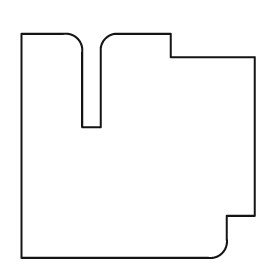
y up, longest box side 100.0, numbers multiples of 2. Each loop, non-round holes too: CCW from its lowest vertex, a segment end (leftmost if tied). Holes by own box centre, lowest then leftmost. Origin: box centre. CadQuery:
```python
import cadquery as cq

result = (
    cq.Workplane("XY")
    .moveTo(-50.0, -48.0)
    .lineTo(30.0, -48.0)
    .threePointArc((36.0, -46.0), (38.0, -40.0))
    .lineTo(38.0, -30.0)
    .lineTo(50.0, -30.0)
    .lineTo(50.0, 38.0)
    .lineTo(14.0, 38.0)
    .lineTo(14.0, 48.0)
    .lineTo(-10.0, 48.0)
    .threePointArc((-14.0, 46.0), (-16.0, 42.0))
    .lineTo(-16.0, 8.0)
    .lineTo(-24.0, 8.0)
    .lineTo(-24.0, 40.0)
    .threePointArc((-26.0, 46.0), (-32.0, 48.0))
    .lineTo(-50.0, 48.0)
    .close()
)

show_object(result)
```